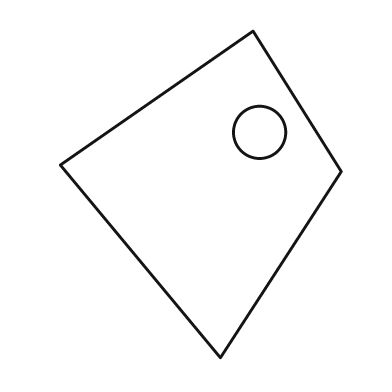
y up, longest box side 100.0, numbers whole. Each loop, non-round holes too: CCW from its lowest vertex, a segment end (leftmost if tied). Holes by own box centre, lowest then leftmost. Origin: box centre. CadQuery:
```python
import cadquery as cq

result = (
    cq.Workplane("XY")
    .moveTo(6.0, -50.0)
    .lineTo(43.0, 7.0)
    .lineTo(16.0, 50.0)
    .lineTo(-43.0, 9.0)
    .close()
    .moveTo(18.0, 19.0)
    .circle(8.0)
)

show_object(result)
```